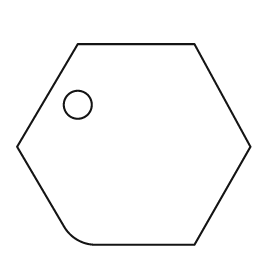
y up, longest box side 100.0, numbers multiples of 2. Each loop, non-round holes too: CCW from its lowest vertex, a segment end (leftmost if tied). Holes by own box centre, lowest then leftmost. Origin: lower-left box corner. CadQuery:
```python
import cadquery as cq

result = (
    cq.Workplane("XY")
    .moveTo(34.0, 0.0)
    .lineTo(76.0, 0.0)
    .lineTo(100.0, 42.0)
    .lineTo(76.0, 86.0)
    .lineTo(26.0, 86.0)
    .lineTo(0.0, 42.0)
    .lineTo(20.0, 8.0)
    .threePointArc((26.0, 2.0), (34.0, 0.0))
    .close()
    .moveTo(26.0, 60.0)
    .circle(6.0)
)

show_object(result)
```